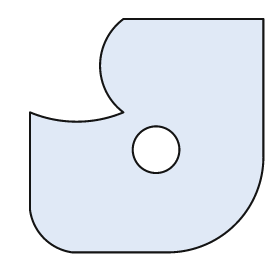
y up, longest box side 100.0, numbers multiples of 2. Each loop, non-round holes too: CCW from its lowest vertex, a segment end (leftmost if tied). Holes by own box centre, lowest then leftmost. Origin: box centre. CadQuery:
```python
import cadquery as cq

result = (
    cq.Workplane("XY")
    .moveTo(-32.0, -50.0)
    .lineTo(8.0, -50.0)
    .threePointArc((38.0, -38.0), (50.0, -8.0))
    .lineTo(50.0, 50.0)
    .lineTo(-10.0, 50.0)
    .threePointArc((-20.0, 30.0), (-10.0, 10.0))
    .threePointArc((-30.0, 6.0), (-50.0, 10.0))
    .lineTo(-50.0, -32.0)
    .threePointArc((-44.0, -44.0), (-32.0, -50.0))
    .close()
    .moveTo(4.0, -6.0)
    .circle(10.0)
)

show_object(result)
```